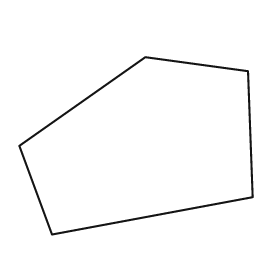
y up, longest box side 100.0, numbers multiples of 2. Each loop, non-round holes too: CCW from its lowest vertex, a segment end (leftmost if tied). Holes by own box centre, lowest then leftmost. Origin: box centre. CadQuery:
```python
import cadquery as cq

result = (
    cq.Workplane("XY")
    .moveTo(-36.0, -38.0)
    .lineTo(50.0, -22.0)
    .lineTo(48.0, 32.0)
    .lineTo(4.0, 38.0)
    .lineTo(-50.0, 0.0)
    .close()
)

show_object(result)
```